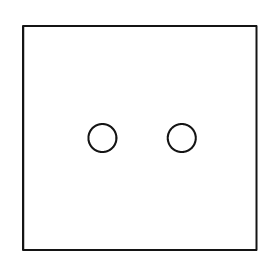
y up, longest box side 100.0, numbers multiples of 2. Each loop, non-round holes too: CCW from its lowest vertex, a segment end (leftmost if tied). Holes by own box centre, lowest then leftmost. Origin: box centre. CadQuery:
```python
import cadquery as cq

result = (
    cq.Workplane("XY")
    .moveTo(-50.0, -48.0)
    .lineTo(50.0, -48.0)
    .lineTo(50.0, 48.0)
    .lineTo(-50.0, 48.0)
    .close()
    .moveTo(-16.0, 0.0)
    .circle(6.0)
    .moveTo(18.0, 0.0)
    .circle(6.0)
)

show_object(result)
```